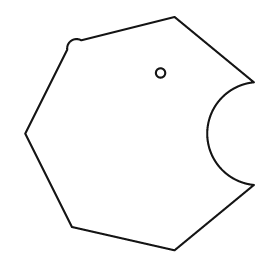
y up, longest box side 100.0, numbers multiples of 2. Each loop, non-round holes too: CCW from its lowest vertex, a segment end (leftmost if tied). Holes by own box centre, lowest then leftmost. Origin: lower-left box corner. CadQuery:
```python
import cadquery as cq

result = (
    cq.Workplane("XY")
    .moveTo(64.0, 0.0)
    .lineTo(98.0, 28.0)
    .threePointArc((78.0, 50.0), (98.0, 72.0))
    .lineTo(64.0, 100.0)
    .lineTo(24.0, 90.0)
    .threePointArc((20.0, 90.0), (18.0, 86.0))
    .lineTo(0.0, 50.0)
    .lineTo(20.0, 10.0)
    .close()
    .moveTo(58.0, 76.0)
    .circle(2.0)
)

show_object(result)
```